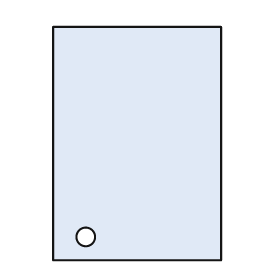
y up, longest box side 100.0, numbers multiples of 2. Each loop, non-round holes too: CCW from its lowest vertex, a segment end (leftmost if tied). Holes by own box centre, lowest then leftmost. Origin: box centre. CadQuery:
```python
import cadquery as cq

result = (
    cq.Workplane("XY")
    .moveTo(-36.0, -50.0)
    .lineTo(36.0, -50.0)
    .lineTo(36.0, 50.0)
    .lineTo(-36.0, 50.0)
    .close()
    .moveTo(-22.0, -40.0)
    .circle(4.0)
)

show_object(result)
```